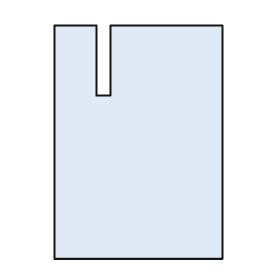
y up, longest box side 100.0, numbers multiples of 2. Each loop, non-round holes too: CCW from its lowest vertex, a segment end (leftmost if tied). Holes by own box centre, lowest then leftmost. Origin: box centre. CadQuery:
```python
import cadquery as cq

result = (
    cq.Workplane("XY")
    .moveTo(-36.0, -50.0)
    .lineTo(36.0, -50.0)
    .lineTo(36.0, 50.0)
    .lineTo(-12.0, 50.0)
    .lineTo(-12.0, 20.0)
    .lineTo(-18.0, 20.0)
    .lineTo(-18.0, 50.0)
    .lineTo(-36.0, 50.0)
    .close()
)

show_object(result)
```